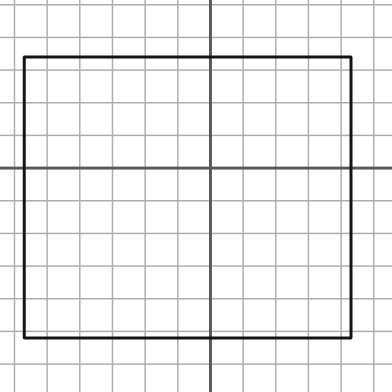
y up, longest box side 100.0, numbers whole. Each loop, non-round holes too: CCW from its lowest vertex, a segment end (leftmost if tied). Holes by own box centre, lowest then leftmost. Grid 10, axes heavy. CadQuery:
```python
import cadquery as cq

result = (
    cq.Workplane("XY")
    .moveTo(-57.0, -52.0)
    .lineTo(43.0, -52.0)
    .lineTo(43.0, 34.0)
    .lineTo(-57.0, 34.0)
    .close()
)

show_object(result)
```